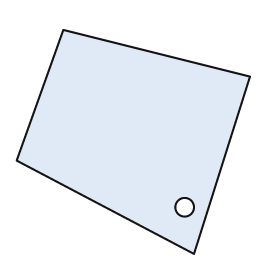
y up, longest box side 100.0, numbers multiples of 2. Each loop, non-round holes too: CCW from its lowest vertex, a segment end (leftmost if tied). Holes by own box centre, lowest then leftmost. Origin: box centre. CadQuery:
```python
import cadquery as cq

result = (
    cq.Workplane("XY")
    .moveTo(26.0, -48.0)
    .lineTo(50.0, 28.0)
    .lineTo(-30.0, 48.0)
    .lineTo(-50.0, -8.0)
    .close()
    .moveTo(22.0, -28.0)
    .circle(4.0)
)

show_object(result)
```